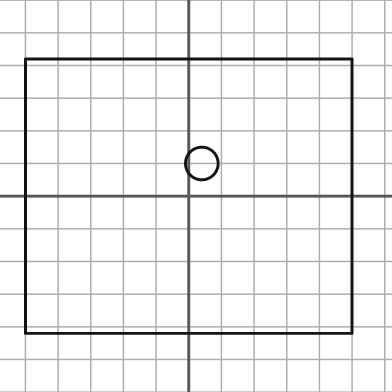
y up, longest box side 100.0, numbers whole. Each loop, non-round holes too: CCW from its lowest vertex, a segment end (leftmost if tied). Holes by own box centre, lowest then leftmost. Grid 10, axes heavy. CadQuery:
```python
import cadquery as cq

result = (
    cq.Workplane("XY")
    .moveTo(-50.0, -42.0)
    .lineTo(50.0, -42.0)
    .lineTo(50.0, 42.0)
    .lineTo(-50.0, 42.0)
    .close()
    .moveTo(4.0, 10.0)
    .circle(5.0)
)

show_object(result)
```